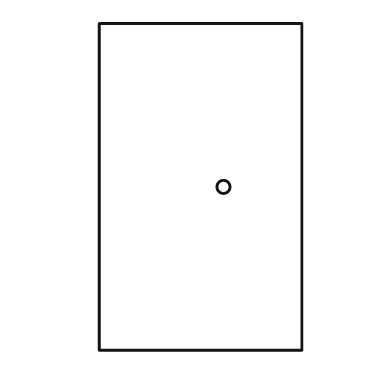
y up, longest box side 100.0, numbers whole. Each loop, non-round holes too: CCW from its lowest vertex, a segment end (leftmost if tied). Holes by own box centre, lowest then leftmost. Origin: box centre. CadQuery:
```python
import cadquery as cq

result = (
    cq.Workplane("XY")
    .moveTo(-31.0, -50.0)
    .lineTo(31.0, -50.0)
    .lineTo(31.0, 50.0)
    .lineTo(-31.0, 50.0)
    .close()
    .moveTo(7.0, 0.0)
    .circle(2.0)
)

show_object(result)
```